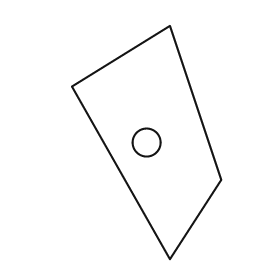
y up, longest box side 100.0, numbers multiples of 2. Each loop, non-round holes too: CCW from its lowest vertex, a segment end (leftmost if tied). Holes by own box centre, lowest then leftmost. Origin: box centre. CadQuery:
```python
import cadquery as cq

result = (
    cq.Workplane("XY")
    .moveTo(10.0, -50.0)
    .lineTo(32.0, -16.0)
    .lineTo(10.0, 50.0)
    .lineTo(-32.0, 24.0)
    .close()
    .moveTo(0.0, 0.0)
    .circle(6.0)
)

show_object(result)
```